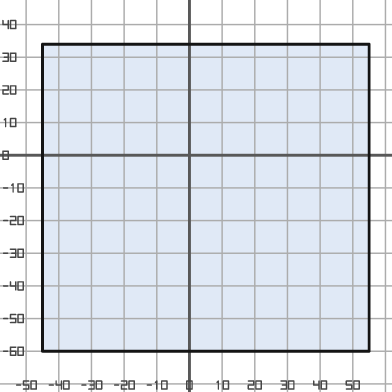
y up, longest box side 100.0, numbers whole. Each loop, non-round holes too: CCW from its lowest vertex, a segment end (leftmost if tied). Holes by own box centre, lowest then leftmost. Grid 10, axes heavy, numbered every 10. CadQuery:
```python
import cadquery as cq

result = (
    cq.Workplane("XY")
    .moveTo(-45.0, -60.0)
    .lineTo(55.0, -60.0)
    .lineTo(55.0, 34.0)
    .lineTo(-45.0, 34.0)
    .close()
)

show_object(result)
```